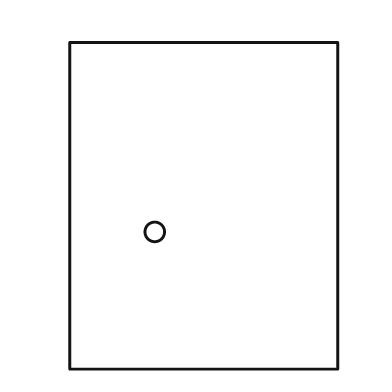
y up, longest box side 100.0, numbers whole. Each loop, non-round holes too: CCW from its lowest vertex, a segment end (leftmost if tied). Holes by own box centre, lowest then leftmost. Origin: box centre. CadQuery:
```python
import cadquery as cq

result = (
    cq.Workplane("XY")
    .moveTo(-41.0, -50.0)
    .lineTo(41.0, -50.0)
    .lineTo(41.0, 50.0)
    .lineTo(-41.0, 50.0)
    .close()
    .moveTo(-15.0, -8.0)
    .circle(3.0)
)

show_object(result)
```